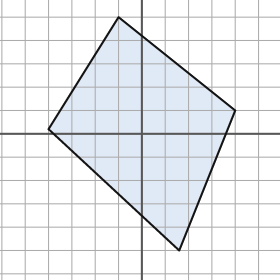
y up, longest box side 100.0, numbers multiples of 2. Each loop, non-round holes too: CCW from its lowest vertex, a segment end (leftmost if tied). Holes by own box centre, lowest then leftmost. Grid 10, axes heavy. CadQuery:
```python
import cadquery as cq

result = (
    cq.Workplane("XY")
    .moveTo(16.0, -50.0)
    .lineTo(40.0, 10.0)
    .lineTo(-10.0, 50.0)
    .lineTo(-40.0, 2.0)
    .close()
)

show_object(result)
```